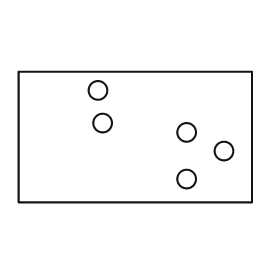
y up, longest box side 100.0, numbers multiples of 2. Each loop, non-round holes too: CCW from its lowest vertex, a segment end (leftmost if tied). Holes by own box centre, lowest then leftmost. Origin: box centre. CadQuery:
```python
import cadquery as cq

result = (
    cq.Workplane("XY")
    .moveTo(-50.0, -28.0)
    .lineTo(50.0, -28.0)
    .lineTo(50.0, 28.0)
    .lineTo(-50.0, 28.0)
    .close()
    .moveTo(22.0, -18.0)
    .circle(4.0)
    .moveTo(38.0, -6.0)
    .circle(4.0)
    .moveTo(22.0, 2.0)
    .circle(4.0)
    .moveTo(-14.0, 6.0)
    .circle(4.0)
    .moveTo(-16.0, 20.0)
    .circle(4.0)
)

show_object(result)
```